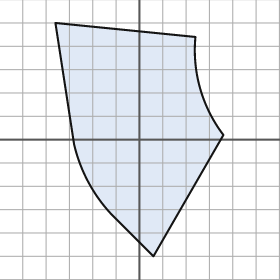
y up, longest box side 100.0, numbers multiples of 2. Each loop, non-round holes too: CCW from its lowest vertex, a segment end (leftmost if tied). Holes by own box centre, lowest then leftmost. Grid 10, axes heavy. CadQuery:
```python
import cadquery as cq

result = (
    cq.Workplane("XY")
    .moveTo(6.0, -50.0)
    .lineTo(36.0, 2.0)
    .threePointArc((26.0, 22.0), (24.0, 44.0))
    .lineTo(-36.0, 50.0)
    .lineTo(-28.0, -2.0)
    .threePointArc((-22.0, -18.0), (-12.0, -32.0))
    .close()
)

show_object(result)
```